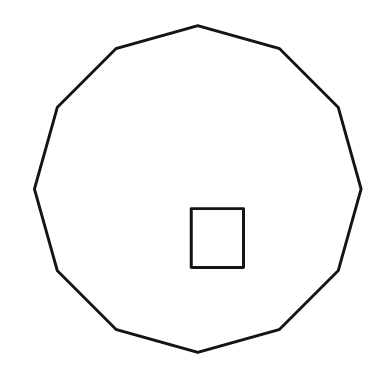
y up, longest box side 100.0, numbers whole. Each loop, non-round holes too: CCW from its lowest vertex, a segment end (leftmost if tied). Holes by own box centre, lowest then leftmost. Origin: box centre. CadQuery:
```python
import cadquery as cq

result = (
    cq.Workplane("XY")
    .moveTo(0.0, -50.0)
    .lineTo(25.0, -43.0)
    .lineTo(43.0, -25.0)
    .lineTo(50.0, 0.0)
    .lineTo(43.0, 25.0)
    .lineTo(25.0, 43.0)
    .lineTo(0.0, 50.0)
    .lineTo(-25.0, 43.0)
    .lineTo(-43.0, 25.0)
    .lineTo(-50.0, 0.0)
    .lineTo(-43.0, -25.0)
    .lineTo(-25.0, -43.0)
    .close()
    .moveTo(-2.0, -24.0)
    .lineTo(14.0, -24.0)
    .lineTo(14.0, -6.0)
    .lineTo(-2.0, -6.0)
    .close()
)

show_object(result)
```